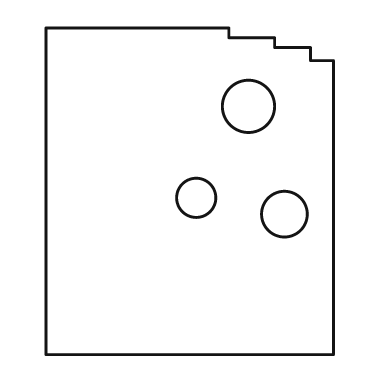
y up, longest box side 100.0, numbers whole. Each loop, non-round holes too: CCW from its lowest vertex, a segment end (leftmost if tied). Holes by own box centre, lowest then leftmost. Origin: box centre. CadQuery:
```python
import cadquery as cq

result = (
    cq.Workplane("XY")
    .moveTo(-44.0, -50.0)
    .lineTo(44.0, -50.0)
    .lineTo(44.0, 40.0)
    .lineTo(37.0, 40.0)
    .lineTo(37.0, 44.0)
    .lineTo(26.0, 44.0)
    .lineTo(26.0, 47.0)
    .lineTo(12.0, 47.0)
    .lineTo(12.0, 50.0)
    .lineTo(-44.0, 50.0)
    .close()
    .moveTo(29.0, -7.0)
    .circle(7.0)
    .moveTo(2.0, -2.0)
    .circle(6.0)
    .moveTo(18.0, 26.0)
    .circle(8.0)
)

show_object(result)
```